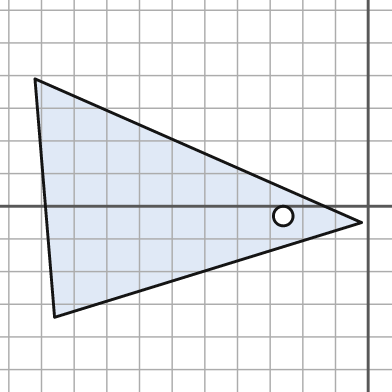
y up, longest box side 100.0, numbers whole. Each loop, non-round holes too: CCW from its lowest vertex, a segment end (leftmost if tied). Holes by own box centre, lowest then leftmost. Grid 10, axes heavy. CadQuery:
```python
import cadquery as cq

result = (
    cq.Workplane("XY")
    .moveTo(-96.0, -34.0)
    .lineTo(-2.0, -5.0)
    .lineTo(-102.0, 39.0)
    .close()
    .moveTo(-26.0, -3.0)
    .circle(3.0)
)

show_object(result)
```